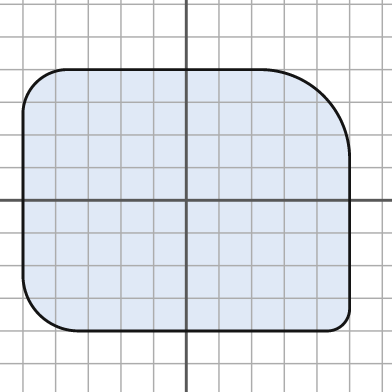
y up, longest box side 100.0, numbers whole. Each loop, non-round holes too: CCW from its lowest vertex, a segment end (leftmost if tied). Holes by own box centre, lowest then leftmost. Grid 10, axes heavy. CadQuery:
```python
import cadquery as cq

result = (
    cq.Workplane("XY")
    .moveTo(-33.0, -40.0)
    .lineTo(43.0, -40.0)
    .threePointArc((48.0, -38.0), (50.0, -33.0))
    .lineTo(50.0, 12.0)
    .threePointArc((42.0, 32.0), (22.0, 40.0))
    .lineTo(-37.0, 40.0)
    .threePointArc((-46.0, 36.0), (-50.0, 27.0))
    .lineTo(-50.0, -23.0)
    .threePointArc((-45.0, -35.0), (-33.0, -40.0))
    .close()
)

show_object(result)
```